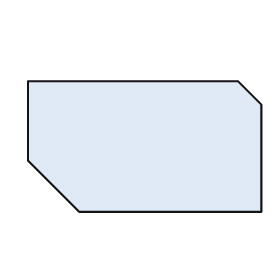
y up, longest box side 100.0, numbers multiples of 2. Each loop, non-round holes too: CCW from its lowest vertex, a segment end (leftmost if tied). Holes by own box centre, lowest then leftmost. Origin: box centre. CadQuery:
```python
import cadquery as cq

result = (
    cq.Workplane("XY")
    .moveTo(-28.0, -28.0)
    .lineTo(50.0, -28.0)
    .lineTo(50.0, 18.0)
    .lineTo(40.0, 28.0)
    .lineTo(-50.0, 28.0)
    .lineTo(-50.0, -6.0)
    .close()
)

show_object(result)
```